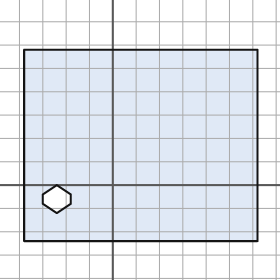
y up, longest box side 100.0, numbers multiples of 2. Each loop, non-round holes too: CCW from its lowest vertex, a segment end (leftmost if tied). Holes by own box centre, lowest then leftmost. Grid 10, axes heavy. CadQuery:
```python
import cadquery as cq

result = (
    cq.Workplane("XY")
    .moveTo(-38.0, -24.0)
    .lineTo(62.0, -24.0)
    .lineTo(62.0, 58.0)
    .lineTo(-38.0, 58.0)
    .close()
    .moveTo(-24.0, -12.0)
    .lineTo(-18.0, -8.0)
    .lineTo(-18.0, -4.0)
    .lineTo(-24.0, 0.0)
    .lineTo(-30.0, -4.0)
    .lineTo(-30.0, -8.0)
    .close()
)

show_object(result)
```